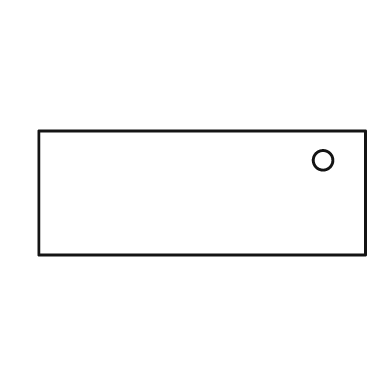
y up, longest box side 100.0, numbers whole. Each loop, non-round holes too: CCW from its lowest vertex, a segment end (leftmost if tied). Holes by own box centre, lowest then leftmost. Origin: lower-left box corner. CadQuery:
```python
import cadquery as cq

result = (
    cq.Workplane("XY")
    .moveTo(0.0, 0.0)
    .lineTo(100.0, 0.0)
    .lineTo(100.0, 38.0)
    .lineTo(0.0, 38.0)
    .close()
    .moveTo(87.0, 29.0)
    .circle(3.0)
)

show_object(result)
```